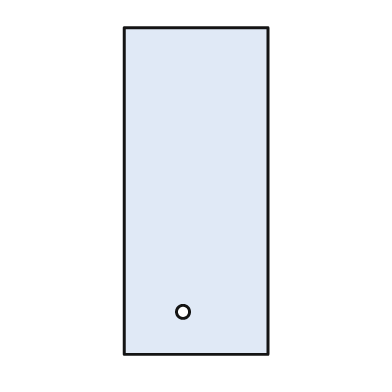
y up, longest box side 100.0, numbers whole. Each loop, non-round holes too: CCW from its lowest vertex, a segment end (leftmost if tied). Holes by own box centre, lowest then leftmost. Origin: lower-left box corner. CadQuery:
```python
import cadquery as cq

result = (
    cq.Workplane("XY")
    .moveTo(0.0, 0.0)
    .lineTo(44.0, 0.0)
    .lineTo(44.0, 100.0)
    .lineTo(0.0, 100.0)
    .close()
    .moveTo(18.0, 13.0)
    .circle(2.0)
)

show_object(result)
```